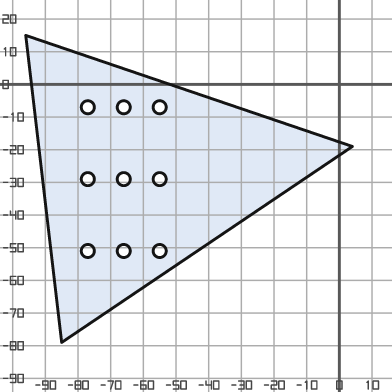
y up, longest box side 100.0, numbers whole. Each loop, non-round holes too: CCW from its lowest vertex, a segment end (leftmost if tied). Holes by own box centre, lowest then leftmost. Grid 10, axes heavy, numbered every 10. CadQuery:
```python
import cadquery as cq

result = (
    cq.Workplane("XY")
    .moveTo(-85.0, -79.0)
    .lineTo(4.0, -19.0)
    .lineTo(-96.0, 15.0)
    .close()
    .moveTo(-77.0, -51.0)
    .circle(2.0)
    .moveTo(-66.0, -51.0)
    .circle(2.0)
    .moveTo(-55.0, -51.0)
    .circle(2.0)
    .moveTo(-77.0, -29.0)
    .circle(2.0)
    .moveTo(-66.0, -29.0)
    .circle(2.0)
    .moveTo(-55.0, -29.0)
    .circle(2.0)
    .moveTo(-77.0, -7.0)
    .circle(2.0)
    .moveTo(-66.0, -7.0)
    .circle(2.0)
    .moveTo(-55.0, -7.0)
    .circle(2.0)
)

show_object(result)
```